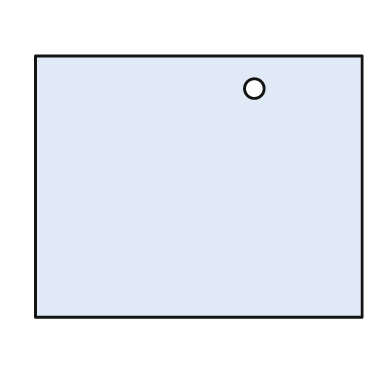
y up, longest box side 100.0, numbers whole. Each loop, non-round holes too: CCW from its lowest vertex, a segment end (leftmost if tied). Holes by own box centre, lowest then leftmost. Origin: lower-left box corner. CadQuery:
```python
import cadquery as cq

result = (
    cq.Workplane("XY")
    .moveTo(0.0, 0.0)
    .lineTo(100.0, 0.0)
    .lineTo(100.0, 80.0)
    .lineTo(0.0, 80.0)
    .close()
    .moveTo(67.0, 70.0)
    .circle(3.0)
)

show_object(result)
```